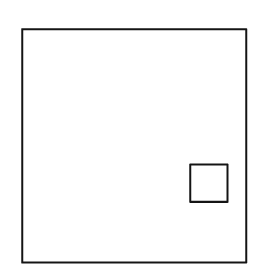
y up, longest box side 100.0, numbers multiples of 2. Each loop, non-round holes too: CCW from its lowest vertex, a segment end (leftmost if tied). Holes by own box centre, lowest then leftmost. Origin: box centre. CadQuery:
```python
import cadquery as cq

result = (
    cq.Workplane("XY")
    .moveTo(-48.0, -50.0)
    .lineTo(48.0, -50.0)
    .lineTo(48.0, 50.0)
    .lineTo(-48.0, 50.0)
    .close()
    .moveTo(24.0, -24.0)
    .lineTo(40.0, -24.0)
    .lineTo(40.0, -8.0)
    .lineTo(24.0, -8.0)
    .close()
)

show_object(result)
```